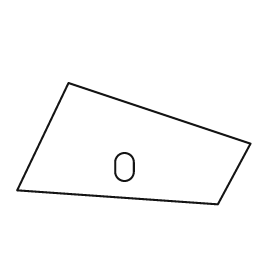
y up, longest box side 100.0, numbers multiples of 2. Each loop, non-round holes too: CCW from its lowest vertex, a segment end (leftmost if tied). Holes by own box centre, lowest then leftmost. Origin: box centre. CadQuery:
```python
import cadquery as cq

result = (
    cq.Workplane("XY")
    .moveTo(36.0, -26.0)
    .lineTo(50.0, 0.0)
    .lineTo(-28.0, 26.0)
    .lineTo(-50.0, -20.0)
    .close()
    .moveTo(-8.0, -12.0)
    .threePointArc((-4.0, -16.0), (0.0, -12.0))
    .lineTo(0.0, -8.0)
    .threePointArc((-4.0, -4.0), (-8.0, -8.0))
    .close()
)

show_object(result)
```